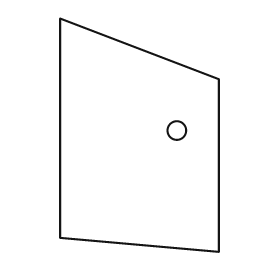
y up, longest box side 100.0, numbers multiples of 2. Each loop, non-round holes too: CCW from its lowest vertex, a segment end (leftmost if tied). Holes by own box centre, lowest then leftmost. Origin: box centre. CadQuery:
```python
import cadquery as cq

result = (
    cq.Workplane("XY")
    .moveTo(34.0, -50.0)
    .lineTo(34.0, 24.0)
    .lineTo(-34.0, 50.0)
    .lineTo(-34.0, -44.0)
    .close()
    .moveTo(16.0, 2.0)
    .circle(4.0)
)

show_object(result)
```